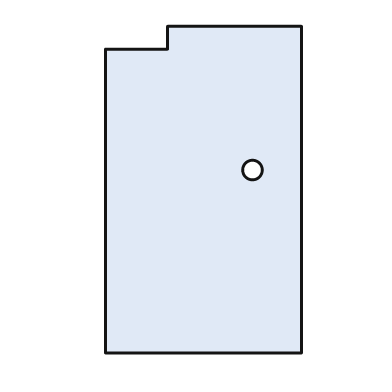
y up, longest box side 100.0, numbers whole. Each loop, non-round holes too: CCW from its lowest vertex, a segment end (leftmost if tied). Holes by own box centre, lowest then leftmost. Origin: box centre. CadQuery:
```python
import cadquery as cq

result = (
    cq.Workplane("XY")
    .moveTo(-30.0, -50.0)
    .lineTo(30.0, -50.0)
    .lineTo(30.0, 50.0)
    .lineTo(-11.0, 50.0)
    .lineTo(-11.0, 43.0)
    .lineTo(-30.0, 43.0)
    .close()
    .moveTo(15.0, 6.0)
    .circle(3.0)
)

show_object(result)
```